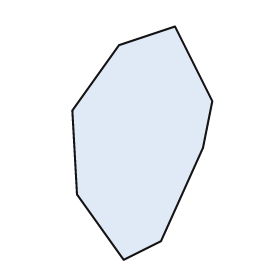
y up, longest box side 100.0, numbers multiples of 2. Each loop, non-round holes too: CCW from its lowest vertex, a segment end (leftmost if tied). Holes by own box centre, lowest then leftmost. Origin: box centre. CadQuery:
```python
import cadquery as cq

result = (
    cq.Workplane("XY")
    .moveTo(-8.0, -50.0)
    .lineTo(8.0, -42.0)
    .lineTo(26.0, -2.0)
    .lineTo(30.0, 18.0)
    .lineTo(14.0, 50.0)
    .lineTo(-10.0, 42.0)
    .lineTo(-30.0, 14.0)
    .lineTo(-28.0, -22.0)
    .close()
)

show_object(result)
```